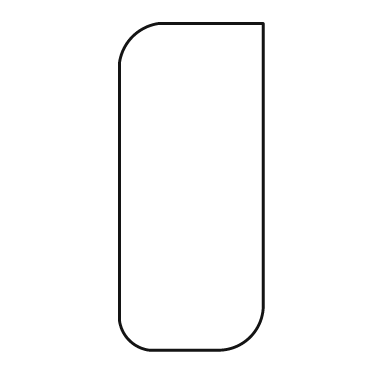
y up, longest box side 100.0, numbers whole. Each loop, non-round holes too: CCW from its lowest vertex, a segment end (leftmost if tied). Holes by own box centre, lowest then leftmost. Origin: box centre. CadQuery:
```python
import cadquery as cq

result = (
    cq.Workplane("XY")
    .moveTo(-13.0, -50.0)
    .lineTo(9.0, -50.0)
    .threePointArc((18.0, -46.0), (22.0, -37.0))
    .lineTo(22.0, 50.0)
    .lineTo(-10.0, 50.0)
    .threePointArc((-18.0, 46.0), (-22.0, 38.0))
    .lineTo(-22.0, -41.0)
    .threePointArc((-19.0, -47.0), (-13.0, -50.0))
    .close()
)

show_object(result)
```